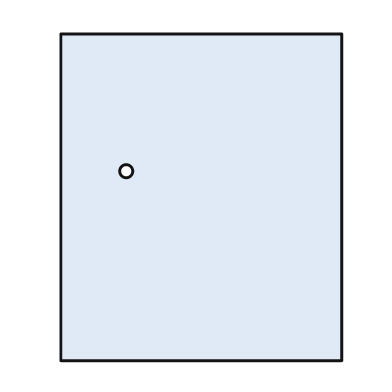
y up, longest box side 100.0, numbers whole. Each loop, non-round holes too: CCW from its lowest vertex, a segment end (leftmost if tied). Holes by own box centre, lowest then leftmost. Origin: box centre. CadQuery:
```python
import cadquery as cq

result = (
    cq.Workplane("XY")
    .moveTo(-43.0, -50.0)
    .lineTo(43.0, -50.0)
    .lineTo(43.0, 50.0)
    .lineTo(-43.0, 50.0)
    .close()
    .moveTo(-23.0, 8.0)
    .circle(2.0)
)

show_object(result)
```